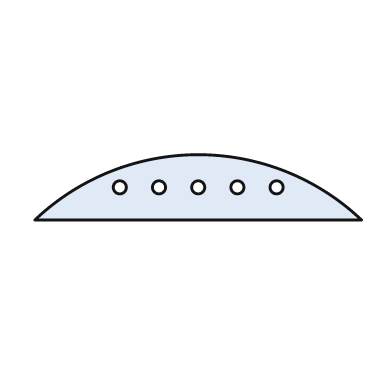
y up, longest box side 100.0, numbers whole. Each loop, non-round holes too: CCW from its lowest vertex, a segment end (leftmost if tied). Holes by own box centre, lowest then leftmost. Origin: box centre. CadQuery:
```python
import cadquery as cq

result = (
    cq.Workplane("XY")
    .moveTo(-50.0, -10.0)
    .lineTo(50.0, -10.0)
    .threePointArc((0.0, 10.0), (-50.0, -10.0))
    .close()
    .moveTo(-24.0, 0.0)
    .circle(2.0)
    .moveTo(-12.0, 0.0)
    .circle(2.0)
    .moveTo(0.0, 0.0)
    .circle(2.0)
    .moveTo(12.0, 0.0)
    .circle(2.0)
    .moveTo(24.0, 0.0)
    .circle(2.0)
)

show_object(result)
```